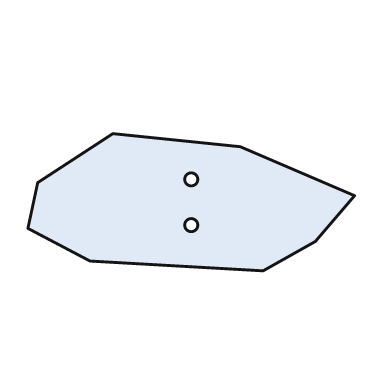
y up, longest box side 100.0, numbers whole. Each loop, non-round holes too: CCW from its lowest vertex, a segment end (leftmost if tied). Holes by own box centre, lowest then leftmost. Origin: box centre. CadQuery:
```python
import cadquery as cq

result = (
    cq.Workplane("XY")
    .moveTo(22.0, -21.0)
    .lineTo(38.0, -12.0)
    .lineTo(50.0, 2.0)
    .lineTo(15.0, 17.0)
    .lineTo(-24.0, 21.0)
    .lineTo(-47.0, 6.0)
    .lineTo(-50.0, -8.0)
    .lineTo(-31.0, -18.0)
    .close()
    .moveTo(0.0, -7.0)
    .circle(2.0)
    .moveTo(0.0, 7.0)
    .circle(2.0)
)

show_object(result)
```